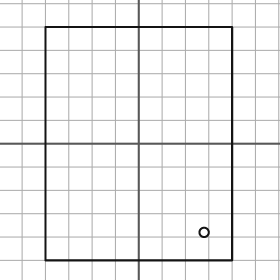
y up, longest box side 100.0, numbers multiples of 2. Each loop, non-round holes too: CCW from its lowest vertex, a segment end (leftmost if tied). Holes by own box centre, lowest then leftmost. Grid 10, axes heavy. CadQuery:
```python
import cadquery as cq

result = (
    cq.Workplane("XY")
    .moveTo(-40.0, -50.0)
    .lineTo(40.0, -50.0)
    .lineTo(40.0, 50.0)
    .lineTo(-40.0, 50.0)
    .close()
    .moveTo(28.0, -38.0)
    .circle(2.0)
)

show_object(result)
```